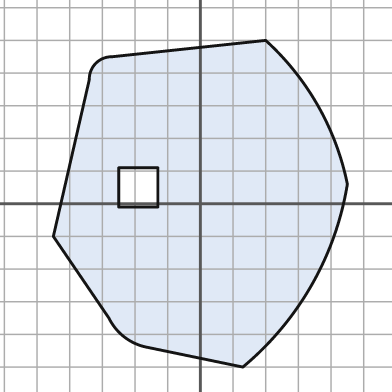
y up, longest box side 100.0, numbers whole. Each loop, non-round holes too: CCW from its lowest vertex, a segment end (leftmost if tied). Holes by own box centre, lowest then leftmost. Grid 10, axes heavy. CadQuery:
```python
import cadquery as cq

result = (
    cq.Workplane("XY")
    .moveTo(13.0, -50.0)
    .threePointArc((34.0, -25.0), (45.0, 6.0))
    .threePointArc((36.0, 30.0), (20.0, 50.0))
    .lineTo(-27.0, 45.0)
    .threePointArc((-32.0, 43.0), (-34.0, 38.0))
    .lineTo(-45.0, -10.0)
    .lineTo(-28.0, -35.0)
    .threePointArc((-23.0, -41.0), (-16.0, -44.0))
    .close()
    .moveTo(-25.0, -1.0)
    .lineTo(-13.0, -1.0)
    .lineTo(-13.0, 11.0)
    .lineTo(-25.0, 11.0)
    .close()
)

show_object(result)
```